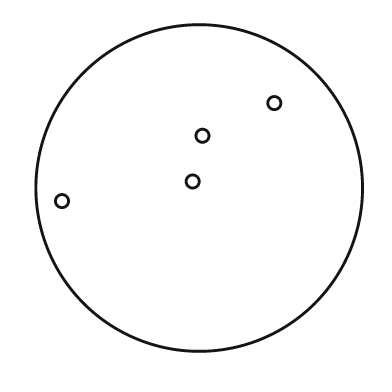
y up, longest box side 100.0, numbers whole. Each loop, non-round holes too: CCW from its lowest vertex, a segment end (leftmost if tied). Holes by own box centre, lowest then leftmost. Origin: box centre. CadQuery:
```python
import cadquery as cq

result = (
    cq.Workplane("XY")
    .moveTo(0.0, 0.0)
    .circle(50.0)
    .moveTo(-42.0, -4.0)
    .circle(2.0)
    .moveTo(-2.0, 2.0)
    .circle(2.0)
    .moveTo(1.0, 16.0)
    .circle(2.0)
    .moveTo(23.0, 26.0)
    .circle(2.0)
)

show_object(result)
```